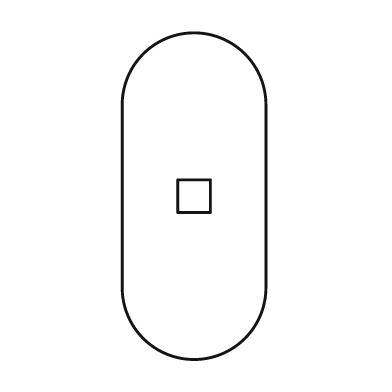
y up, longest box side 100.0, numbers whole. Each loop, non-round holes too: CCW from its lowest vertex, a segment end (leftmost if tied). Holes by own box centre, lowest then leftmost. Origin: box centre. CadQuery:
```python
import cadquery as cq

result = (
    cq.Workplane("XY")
    .moveTo(-22.0, -28.0)
    .threePointArc((0.0, -50.0), (22.0, -28.0))
    .lineTo(22.0, 28.0)
    .threePointArc((0.0, 50.0), (-22.0, 28.0))
    .close()
    .moveTo(-5.0, -5.0)
    .lineTo(5.0, -5.0)
    .lineTo(5.0, 5.0)
    .lineTo(-5.0, 5.0)
    .close()
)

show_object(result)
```